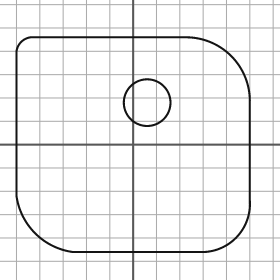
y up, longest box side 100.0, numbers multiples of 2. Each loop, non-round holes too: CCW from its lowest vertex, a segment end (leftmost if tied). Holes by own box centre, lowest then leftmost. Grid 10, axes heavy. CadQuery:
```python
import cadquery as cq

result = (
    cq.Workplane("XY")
    .moveTo(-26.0, -46.0)
    .lineTo(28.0, -46.0)
    .threePointArc((44.0, -40.0), (50.0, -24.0))
    .lineTo(50.0, 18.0)
    .threePointArc((42.0, 38.0), (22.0, 46.0))
    .lineTo(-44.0, 46.0)
    .threePointArc((-48.0, 44.0), (-50.0, 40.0))
    .lineTo(-50.0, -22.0)
    .threePointArc((-42.0, -38.0), (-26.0, -46.0))
    .close()
    .moveTo(6.0, 18.0)
    .circle(10.0)
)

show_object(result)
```